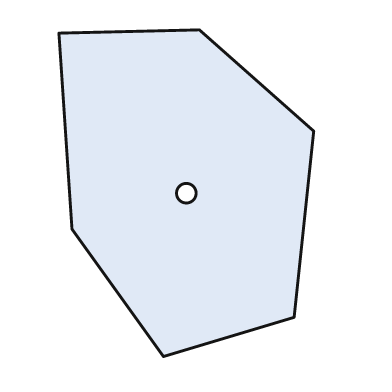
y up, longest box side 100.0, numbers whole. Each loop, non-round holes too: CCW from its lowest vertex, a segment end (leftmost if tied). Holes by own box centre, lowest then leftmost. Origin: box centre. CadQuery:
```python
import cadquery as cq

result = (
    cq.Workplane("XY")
    .moveTo(-7.0, -50.0)
    .lineTo(33.0, -38.0)
    .lineTo(39.0, 19.0)
    .lineTo(4.0, 50.0)
    .lineTo(-39.0, 49.0)
    .lineTo(-35.0, -11.0)
    .close()
    .moveTo(0.0, 0.0)
    .circle(3.0)
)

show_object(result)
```